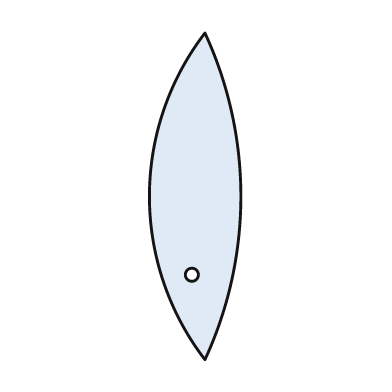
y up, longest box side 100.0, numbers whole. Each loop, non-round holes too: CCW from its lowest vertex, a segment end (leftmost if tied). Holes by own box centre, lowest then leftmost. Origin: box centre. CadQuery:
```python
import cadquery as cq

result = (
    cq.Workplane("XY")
    .moveTo(3.0, -50.0)
    .threePointArc((14.0, 0.0), (3.0, 50.0))
    .threePointArc((-14.0, 0.0), (3.0, -50.0))
    .close()
    .moveTo(-1.0, -24.0)
    .circle(2.0)
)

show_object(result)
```